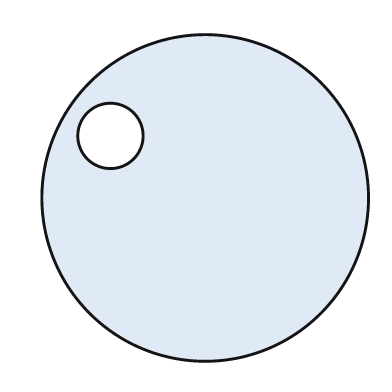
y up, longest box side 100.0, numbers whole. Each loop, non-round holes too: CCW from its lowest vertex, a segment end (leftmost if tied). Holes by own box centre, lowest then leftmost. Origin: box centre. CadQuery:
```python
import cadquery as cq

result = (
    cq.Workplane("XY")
    .moveTo(0.0, 0.0)
    .circle(50.0)
    .moveTo(-29.0, 19.0)
    .circle(10.0)
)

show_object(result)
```